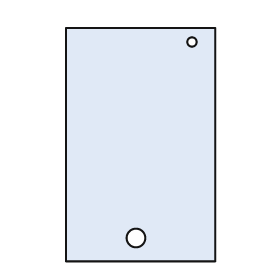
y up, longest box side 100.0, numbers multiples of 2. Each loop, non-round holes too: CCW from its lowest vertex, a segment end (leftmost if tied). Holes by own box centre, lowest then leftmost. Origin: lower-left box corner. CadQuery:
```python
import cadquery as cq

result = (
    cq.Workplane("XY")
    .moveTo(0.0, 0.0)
    .lineTo(64.0, 0.0)
    .lineTo(64.0, 100.0)
    .lineTo(0.0, 100.0)
    .close()
    .moveTo(30.0, 10.0)
    .circle(4.0)
    .moveTo(54.0, 94.0)
    .circle(2.0)
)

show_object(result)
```